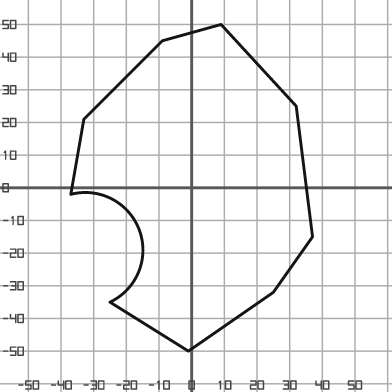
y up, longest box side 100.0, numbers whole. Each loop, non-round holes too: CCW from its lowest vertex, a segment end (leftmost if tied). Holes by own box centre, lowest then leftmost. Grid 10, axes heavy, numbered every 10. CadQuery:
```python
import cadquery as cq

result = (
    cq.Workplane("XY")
    .moveTo(-1.0, -50.0)
    .lineTo(25.0, -32.0)
    .lineTo(37.0, -15.0)
    .lineTo(32.0, 25.0)
    .lineTo(9.0, 50.0)
    .lineTo(-9.0, 45.0)
    .lineTo(-33.0, 21.0)
    .lineTo(-37.0, -2.0)
    .threePointArc((-16.0, -13.0), (-25.0, -35.0))
    .close()
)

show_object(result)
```